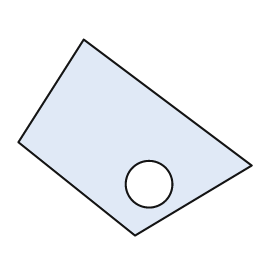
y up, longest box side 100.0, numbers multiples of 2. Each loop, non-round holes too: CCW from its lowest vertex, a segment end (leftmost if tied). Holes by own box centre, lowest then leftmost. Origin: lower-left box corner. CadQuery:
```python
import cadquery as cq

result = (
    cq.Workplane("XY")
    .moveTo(50.0, 0.0)
    .lineTo(100.0, 30.0)
    .lineTo(28.0, 84.0)
    .lineTo(0.0, 40.0)
    .close()
    .moveTo(56.0, 22.0)
    .circle(10.0)
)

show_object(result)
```